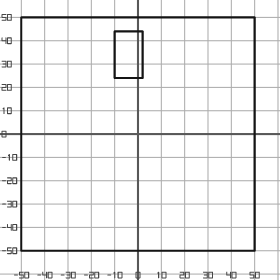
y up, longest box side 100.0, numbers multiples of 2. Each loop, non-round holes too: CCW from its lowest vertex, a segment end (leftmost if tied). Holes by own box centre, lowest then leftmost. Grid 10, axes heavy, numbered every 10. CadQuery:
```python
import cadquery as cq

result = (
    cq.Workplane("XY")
    .moveTo(-50.0, -50.0)
    .lineTo(50.0, -50.0)
    .lineTo(50.0, 50.0)
    .lineTo(-50.0, 50.0)
    .close()
    .moveTo(-10.0, 24.0)
    .lineTo(2.0, 24.0)
    .lineTo(2.0, 44.0)
    .lineTo(-10.0, 44.0)
    .close()
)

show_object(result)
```